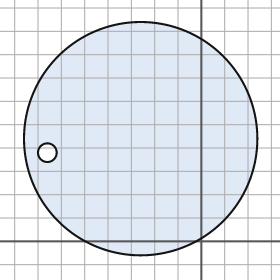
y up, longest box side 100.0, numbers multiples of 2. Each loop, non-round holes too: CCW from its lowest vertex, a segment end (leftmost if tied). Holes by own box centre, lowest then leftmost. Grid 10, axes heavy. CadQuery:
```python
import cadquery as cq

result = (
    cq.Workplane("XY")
    .moveTo(-26.0, 44.0)
    .circle(50.0)
    .moveTo(-66.0, 38.0)
    .circle(4.0)
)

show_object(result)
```